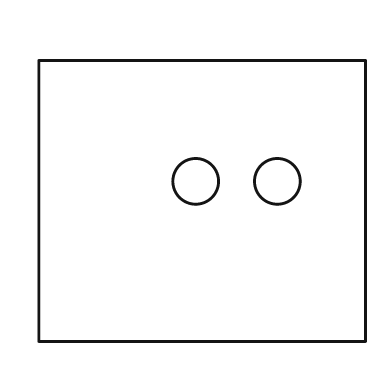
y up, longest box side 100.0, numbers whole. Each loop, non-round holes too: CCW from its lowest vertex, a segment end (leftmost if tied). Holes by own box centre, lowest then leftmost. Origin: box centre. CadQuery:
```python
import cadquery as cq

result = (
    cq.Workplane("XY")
    .moveTo(-50.0, -43.0)
    .lineTo(50.0, -43.0)
    .lineTo(50.0, 43.0)
    .lineTo(-50.0, 43.0)
    .close()
    .moveTo(-2.0, 6.0)
    .circle(7.0)
    .moveTo(23.0, 6.0)
    .circle(7.0)
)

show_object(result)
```